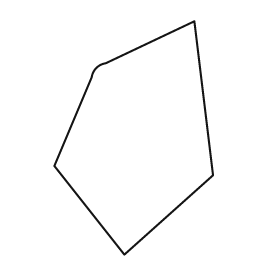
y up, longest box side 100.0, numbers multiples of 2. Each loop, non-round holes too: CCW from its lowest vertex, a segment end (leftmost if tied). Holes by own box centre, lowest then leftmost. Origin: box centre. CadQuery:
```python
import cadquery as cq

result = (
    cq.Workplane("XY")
    .moveTo(-4.0, -50.0)
    .lineTo(34.0, -16.0)
    .lineTo(26.0, 50.0)
    .lineTo(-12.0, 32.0)
    .threePointArc((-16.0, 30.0), (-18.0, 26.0))
    .lineTo(-34.0, -12.0)
    .close()
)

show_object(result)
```